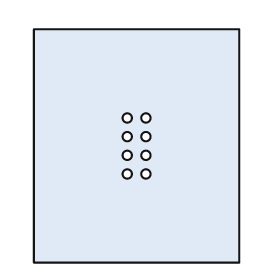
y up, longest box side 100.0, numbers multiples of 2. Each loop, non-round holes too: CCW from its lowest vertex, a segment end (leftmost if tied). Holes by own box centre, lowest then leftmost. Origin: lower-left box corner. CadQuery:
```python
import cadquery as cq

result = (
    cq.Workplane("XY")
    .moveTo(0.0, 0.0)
    .lineTo(88.0, 0.0)
    .lineTo(88.0, 100.0)
    .lineTo(0.0, 100.0)
    .close()
    .moveTo(40.0, 38.0)
    .circle(2.0)
    .moveTo(48.0, 38.0)
    .circle(2.0)
    .moveTo(40.0, 46.0)
    .circle(2.0)
    .moveTo(48.0, 46.0)
    .circle(2.0)
    .moveTo(40.0, 54.0)
    .circle(2.0)
    .moveTo(48.0, 54.0)
    .circle(2.0)
    .moveTo(40.0, 62.0)
    .circle(2.0)
    .moveTo(48.0, 62.0)
    .circle(2.0)
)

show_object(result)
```